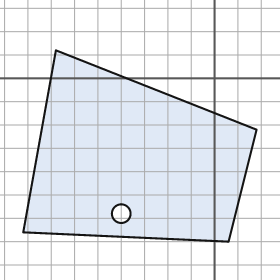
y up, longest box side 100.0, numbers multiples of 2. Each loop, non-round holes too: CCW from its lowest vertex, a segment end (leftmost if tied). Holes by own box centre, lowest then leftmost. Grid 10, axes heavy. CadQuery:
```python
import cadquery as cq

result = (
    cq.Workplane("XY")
    .moveTo(6.0, -70.0)
    .lineTo(18.0, -22.0)
    .lineTo(-68.0, 12.0)
    .lineTo(-82.0, -66.0)
    .close()
    .moveTo(-40.0, -58.0)
    .circle(4.0)
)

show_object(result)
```